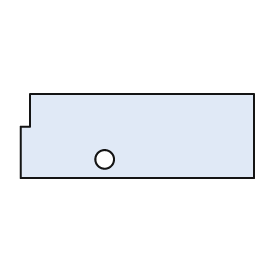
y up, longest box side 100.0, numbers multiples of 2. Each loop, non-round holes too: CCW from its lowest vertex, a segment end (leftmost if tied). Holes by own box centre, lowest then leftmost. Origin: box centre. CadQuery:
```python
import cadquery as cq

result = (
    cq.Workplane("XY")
    .moveTo(-50.0, -18.0)
    .lineTo(50.0, -18.0)
    .lineTo(50.0, 18.0)
    .lineTo(-46.0, 18.0)
    .lineTo(-46.0, 4.0)
    .lineTo(-50.0, 4.0)
    .close()
    .moveTo(-14.0, -10.0)
    .circle(4.0)
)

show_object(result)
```